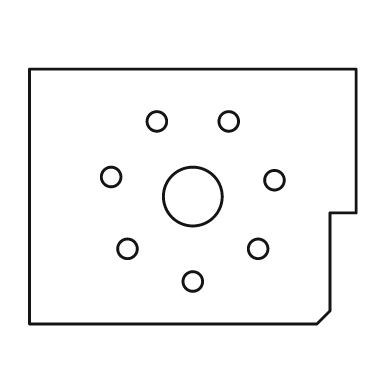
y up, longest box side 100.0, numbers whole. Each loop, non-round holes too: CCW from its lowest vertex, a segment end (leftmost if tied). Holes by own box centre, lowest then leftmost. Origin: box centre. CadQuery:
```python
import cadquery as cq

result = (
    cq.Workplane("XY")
    .moveTo(-50.0, -39.0)
    .lineTo(38.0, -39.0)
    .lineTo(42.0, -35.0)
    .lineTo(42.0, -5.0)
    .lineTo(50.0, -5.0)
    .lineTo(50.0, 39.0)
    .lineTo(-50.0, 39.0)
    .close()
    .moveTo(0.0, -26.0)
    .circle(3.0)
    .moveTo(-20.0, -16.0)
    .circle(3.0)
    .moveTo(20.0, -16.0)
    .circle(3.0)
    .moveTo(0.0, 0.0)
    .circle(9.0)
    .moveTo(25.0, 5.0)
    .circle(3.0)
    .moveTo(-25.0, 6.0)
    .circle(3.0)
    .moveTo(-11.0, 23.0)
    .circle(3.0)
    .moveTo(11.0, 23.0)
    .circle(3.0)
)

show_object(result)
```